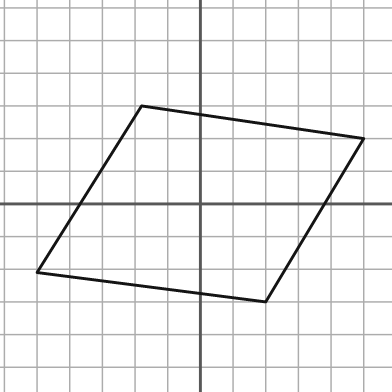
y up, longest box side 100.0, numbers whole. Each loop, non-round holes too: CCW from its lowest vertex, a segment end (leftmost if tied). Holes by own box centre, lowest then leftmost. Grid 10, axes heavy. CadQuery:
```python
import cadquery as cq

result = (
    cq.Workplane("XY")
    .moveTo(20.0, -30.0)
    .lineTo(50.0, 20.0)
    .lineTo(-18.0, 30.0)
    .lineTo(-50.0, -21.0)
    .close()
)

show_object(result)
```